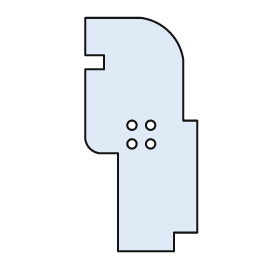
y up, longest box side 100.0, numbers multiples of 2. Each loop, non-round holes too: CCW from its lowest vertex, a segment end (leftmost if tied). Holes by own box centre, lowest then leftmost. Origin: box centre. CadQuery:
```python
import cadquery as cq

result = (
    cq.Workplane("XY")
    .moveTo(-10.0, -50.0)
    .lineTo(14.0, -50.0)
    .lineTo(14.0, -42.0)
    .lineTo(24.0, -42.0)
    .lineTo(24.0, 6.0)
    .lineTo(18.0, 6.0)
    .lineTo(18.0, 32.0)
    .threePointArc((12.0, 44.0), (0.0, 50.0))
    .lineTo(-24.0, 50.0)
    .lineTo(-24.0, 34.0)
    .lineTo(-16.0, 34.0)
    .lineTo(-16.0, 28.0)
    .lineTo(-24.0, 28.0)
    .lineTo(-24.0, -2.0)
    .threePointArc((-22.0, -6.0), (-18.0, -8.0))
    .lineTo(-10.0, -8.0)
    .close()
    .moveTo(-4.0, -4.0)
    .circle(2.0)
    .moveTo(4.0, -4.0)
    .circle(2.0)
    .moveTo(-4.0, 4.0)
    .circle(2.0)
    .moveTo(4.0, 4.0)
    .circle(2.0)
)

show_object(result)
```